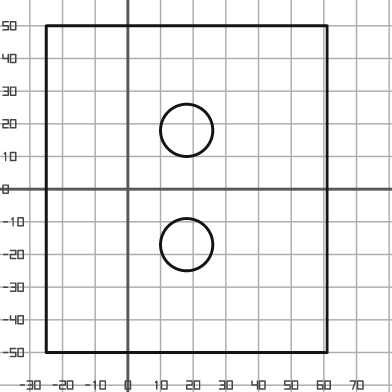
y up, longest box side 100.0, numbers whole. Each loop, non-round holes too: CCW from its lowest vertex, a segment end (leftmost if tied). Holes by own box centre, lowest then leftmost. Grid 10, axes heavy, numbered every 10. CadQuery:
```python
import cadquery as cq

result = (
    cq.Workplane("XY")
    .moveTo(-25.0, -50.0)
    .lineTo(61.0, -50.0)
    .lineTo(61.0, 50.0)
    .lineTo(-25.0, 50.0)
    .close()
    .moveTo(18.0, -17.0)
    .circle(8.0)
    .moveTo(18.0, 18.0)
    .circle(8.0)
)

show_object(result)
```